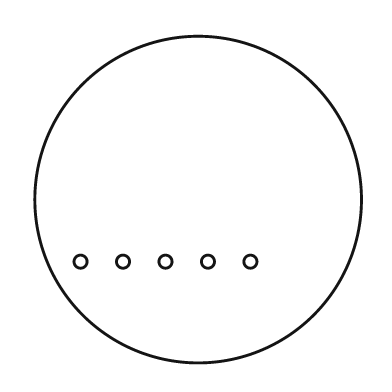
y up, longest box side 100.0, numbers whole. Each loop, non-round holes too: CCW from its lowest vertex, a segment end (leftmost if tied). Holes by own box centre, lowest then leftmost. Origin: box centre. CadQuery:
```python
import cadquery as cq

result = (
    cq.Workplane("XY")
    .moveTo(0.0, 0.0)
    .circle(50.0)
    .moveTo(-36.0, -19.0)
    .circle(2.0)
    .moveTo(-23.0, -19.0)
    .circle(2.0)
    .moveTo(-10.0, -19.0)
    .circle(2.0)
    .moveTo(3.0, -19.0)
    .circle(2.0)
    .moveTo(16.0, -19.0)
    .circle(2.0)
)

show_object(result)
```